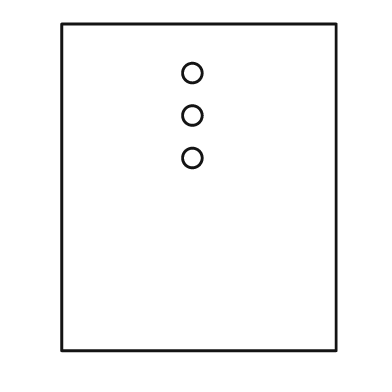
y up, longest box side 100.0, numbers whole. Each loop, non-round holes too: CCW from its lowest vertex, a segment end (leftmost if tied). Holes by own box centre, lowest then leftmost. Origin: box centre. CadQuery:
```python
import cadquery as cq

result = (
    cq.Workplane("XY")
    .moveTo(-42.0, -50.0)
    .lineTo(42.0, -50.0)
    .lineTo(42.0, 50.0)
    .lineTo(-42.0, 50.0)
    .close()
    .moveTo(-2.0, 9.0)
    .circle(3.0)
    .moveTo(-2.0, 22.0)
    .circle(3.0)
    .moveTo(-2.0, 35.0)
    .circle(3.0)
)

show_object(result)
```